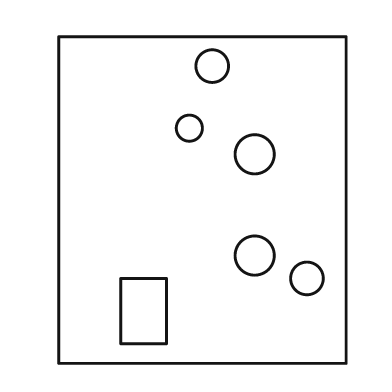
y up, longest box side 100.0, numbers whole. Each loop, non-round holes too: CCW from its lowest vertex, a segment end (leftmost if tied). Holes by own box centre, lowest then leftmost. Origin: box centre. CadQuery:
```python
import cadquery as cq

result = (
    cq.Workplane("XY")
    .moveTo(-44.0, -50.0)
    .lineTo(44.0, -50.0)
    .lineTo(44.0, 50.0)
    .lineTo(-44.0, 50.0)
    .close()
    .moveTo(-25.0, -44.0)
    .lineTo(-11.0, -44.0)
    .lineTo(-11.0, -24.0)
    .lineTo(-25.0, -24.0)
    .close()
    .moveTo(32.0, -24.0)
    .circle(5.0)
    .moveTo(16.0, -17.0)
    .circle(6.0)
    .moveTo(16.0, 14.0)
    .circle(6.0)
    .moveTo(-4.0, 22.0)
    .circle(4.0)
    .moveTo(3.0, 41.0)
    .circle(5.0)
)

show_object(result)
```